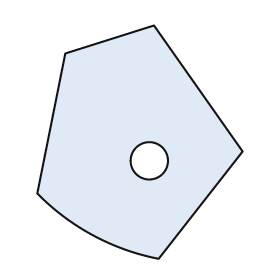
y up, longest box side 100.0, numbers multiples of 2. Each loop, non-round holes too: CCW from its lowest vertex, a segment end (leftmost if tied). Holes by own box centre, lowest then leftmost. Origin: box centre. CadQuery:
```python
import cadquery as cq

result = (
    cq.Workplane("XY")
    .moveTo(8.0, -50.0)
    .lineTo(44.0, -4.0)
    .lineTo(6.0, 50.0)
    .lineTo(-32.0, 38.0)
    .lineTo(-44.0, -22.0)
    .threePointArc((-20.0, -40.0), (8.0, -50.0))
    .close()
    .moveTo(4.0, -8.0)
    .circle(8.0)
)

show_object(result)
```